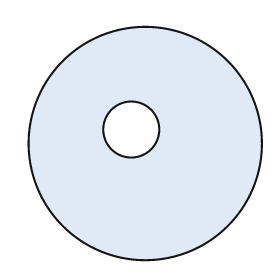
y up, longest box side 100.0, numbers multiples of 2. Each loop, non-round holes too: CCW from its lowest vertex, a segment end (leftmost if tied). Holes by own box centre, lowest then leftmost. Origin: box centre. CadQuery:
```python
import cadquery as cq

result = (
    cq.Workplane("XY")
    .moveTo(0.0, 0.0)
    .circle(50.0)
    .moveTo(-6.0, 6.0)
    .circle(12.0)
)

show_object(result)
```